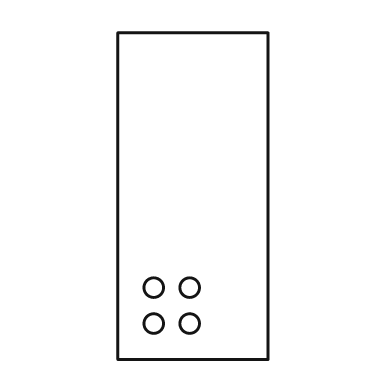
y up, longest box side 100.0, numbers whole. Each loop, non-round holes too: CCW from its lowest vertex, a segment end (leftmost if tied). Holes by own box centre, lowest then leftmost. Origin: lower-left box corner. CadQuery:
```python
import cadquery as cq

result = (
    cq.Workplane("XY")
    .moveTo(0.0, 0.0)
    .lineTo(46.0, 0.0)
    .lineTo(46.0, 100.0)
    .lineTo(0.0, 100.0)
    .close()
    .moveTo(11.0, 11.0)
    .circle(3.0)
    .moveTo(22.0, 11.0)
    .circle(3.0)
    .moveTo(11.0, 22.0)
    .circle(3.0)
    .moveTo(22.0, 22.0)
    .circle(3.0)
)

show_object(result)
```